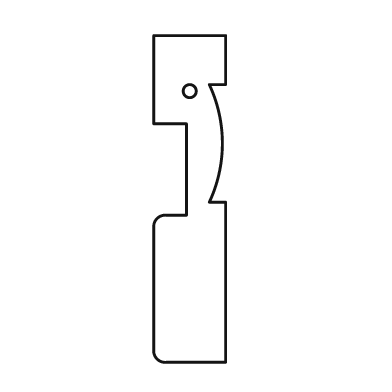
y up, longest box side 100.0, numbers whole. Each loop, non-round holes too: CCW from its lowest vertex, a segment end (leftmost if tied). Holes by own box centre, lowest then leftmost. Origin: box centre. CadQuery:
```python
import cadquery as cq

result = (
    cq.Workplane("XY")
    .moveTo(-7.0, -50.0)
    .lineTo(11.0, -50.0)
    .lineTo(11.0, -1.0)
    .lineTo(6.0, -1.0)
    .threePointArc((10.0, 17.0), (6.0, 35.0))
    .lineTo(11.0, 35.0)
    .lineTo(11.0, 50.0)
    .lineTo(-11.0, 50.0)
    .lineTo(-11.0, 23.0)
    .lineTo(-1.0, 23.0)
    .lineTo(-1.0, -5.0)
    .lineTo(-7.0, -5.0)
    .threePointArc((-10.0, -6.0), (-11.0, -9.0))
    .lineTo(-11.0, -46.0)
    .threePointArc((-10.0, -49.0), (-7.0, -50.0))
    .close()
    .moveTo(0.0, 33.0)
    .circle(2.0)
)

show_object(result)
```